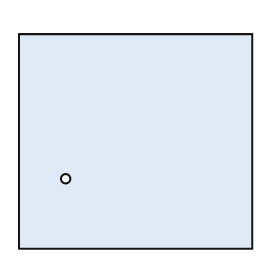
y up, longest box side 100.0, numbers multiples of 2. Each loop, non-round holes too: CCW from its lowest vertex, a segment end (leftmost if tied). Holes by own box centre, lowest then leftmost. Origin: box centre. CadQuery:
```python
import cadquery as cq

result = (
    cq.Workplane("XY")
    .moveTo(-50.0, -46.0)
    .lineTo(50.0, -46.0)
    .lineTo(50.0, 46.0)
    .lineTo(-50.0, 46.0)
    .close()
    .moveTo(-30.0, -16.0)
    .circle(2.0)
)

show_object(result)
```